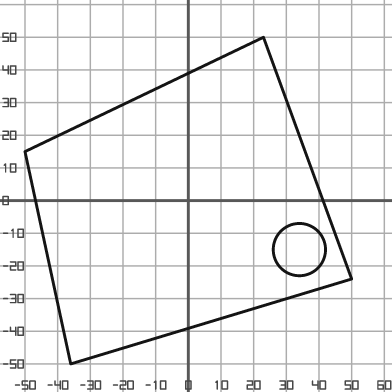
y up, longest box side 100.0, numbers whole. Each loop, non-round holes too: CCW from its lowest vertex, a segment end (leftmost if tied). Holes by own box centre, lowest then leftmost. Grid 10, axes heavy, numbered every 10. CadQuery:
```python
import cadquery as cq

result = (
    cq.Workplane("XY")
    .moveTo(-36.0, -50.0)
    .lineTo(50.0, -24.0)
    .lineTo(23.0, 50.0)
    .lineTo(-50.0, 15.0)
    .close()
    .moveTo(34.0, -15.0)
    .circle(8.0)
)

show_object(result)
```